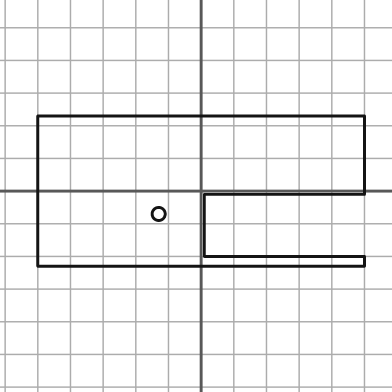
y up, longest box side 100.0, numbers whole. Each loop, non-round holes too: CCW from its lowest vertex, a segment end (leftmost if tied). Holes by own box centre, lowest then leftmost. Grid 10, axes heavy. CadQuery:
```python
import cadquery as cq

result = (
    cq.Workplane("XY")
    .moveTo(-50.0, -23.0)
    .lineTo(50.0, -23.0)
    .lineTo(50.0, -20.0)
    .lineTo(1.0, -20.0)
    .lineTo(1.0, -1.0)
    .lineTo(50.0, -1.0)
    .lineTo(50.0, 23.0)
    .lineTo(-50.0, 23.0)
    .close()
    .moveTo(-13.0, -7.0)
    .circle(2.0)
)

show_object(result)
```